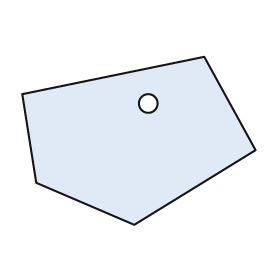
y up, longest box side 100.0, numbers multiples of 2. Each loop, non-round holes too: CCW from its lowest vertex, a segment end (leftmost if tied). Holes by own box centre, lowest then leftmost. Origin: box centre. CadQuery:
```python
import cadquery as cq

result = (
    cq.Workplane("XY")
    .moveTo(-2.0, -36.0)
    .lineTo(50.0, -4.0)
    .lineTo(28.0, 36.0)
    .lineTo(-50.0, 20.0)
    .lineTo(-44.0, -18.0)
    .close()
    .moveTo(4.0, 16.0)
    .circle(4.0)
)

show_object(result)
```